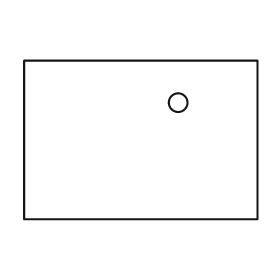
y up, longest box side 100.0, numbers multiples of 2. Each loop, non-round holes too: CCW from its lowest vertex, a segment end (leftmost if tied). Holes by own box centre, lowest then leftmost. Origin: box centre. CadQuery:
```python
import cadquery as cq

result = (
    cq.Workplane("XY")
    .moveTo(-50.0, -34.0)
    .lineTo(50.0, -34.0)
    .lineTo(50.0, 34.0)
    .lineTo(-50.0, 34.0)
    .close()
    .moveTo(16.0, 16.0)
    .circle(4.0)
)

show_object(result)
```